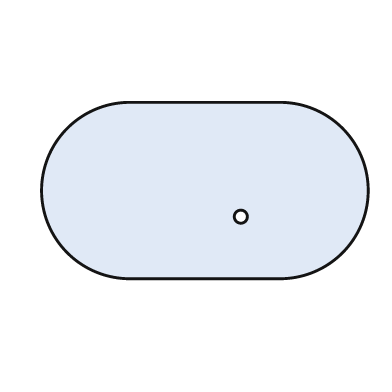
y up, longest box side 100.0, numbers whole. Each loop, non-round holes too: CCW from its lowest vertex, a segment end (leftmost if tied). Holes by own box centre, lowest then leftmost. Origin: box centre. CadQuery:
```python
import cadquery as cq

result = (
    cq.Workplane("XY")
    .moveTo(-23.0, -27.0)
    .lineTo(23.0, -27.0)
    .threePointArc((50.0, 0.0), (23.0, 27.0))
    .lineTo(-23.0, 27.0)
    .threePointArc((-50.0, 0.0), (-23.0, -27.0))
    .close()
    .moveTo(11.0, -8.0)
    .circle(2.0)
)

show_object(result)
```